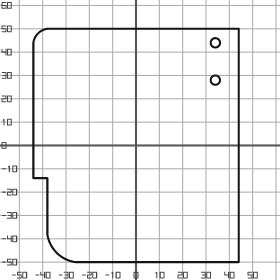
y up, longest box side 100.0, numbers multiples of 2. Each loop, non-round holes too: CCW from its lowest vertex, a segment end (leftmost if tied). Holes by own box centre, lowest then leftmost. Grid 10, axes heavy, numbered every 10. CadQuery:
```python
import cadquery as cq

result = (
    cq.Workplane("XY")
    .moveTo(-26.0, -50.0)
    .lineTo(44.0, -50.0)
    .lineTo(44.0, 50.0)
    .lineTo(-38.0, 50.0)
    .threePointArc((-42.0, 48.0), (-44.0, 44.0))
    .lineTo(-44.0, -14.0)
    .lineTo(-38.0, -14.0)
    .lineTo(-38.0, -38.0)
    .threePointArc((-34.0, -46.0), (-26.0, -50.0))
    .close()
    .moveTo(34.0, 28.0)
    .circle(2.0)
    .moveTo(34.0, 44.0)
    .circle(2.0)
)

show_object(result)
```